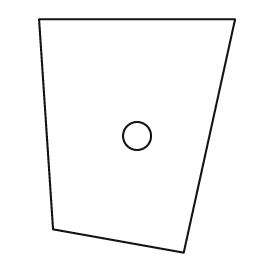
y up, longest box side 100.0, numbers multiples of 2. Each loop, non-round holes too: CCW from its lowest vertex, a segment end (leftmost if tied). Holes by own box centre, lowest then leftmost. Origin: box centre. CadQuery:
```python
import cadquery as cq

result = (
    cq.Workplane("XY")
    .moveTo(20.0, -50.0)
    .lineTo(42.0, 50.0)
    .lineTo(-42.0, 50.0)
    .lineTo(-36.0, -40.0)
    .close()
    .moveTo(0.0, 0.0)
    .circle(6.0)
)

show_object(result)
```